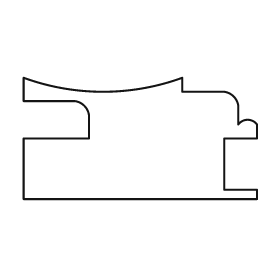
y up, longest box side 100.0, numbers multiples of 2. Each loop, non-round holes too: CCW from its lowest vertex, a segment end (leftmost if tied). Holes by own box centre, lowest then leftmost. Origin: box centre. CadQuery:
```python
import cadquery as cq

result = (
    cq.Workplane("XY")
    .moveTo(-50.0, -26.0)
    .lineTo(50.0, -26.0)
    .lineTo(50.0, -22.0)
    .lineTo(36.0, -22.0)
    .lineTo(36.0, 0.0)
    .lineTo(50.0, 0.0)
    .lineTo(50.0, 6.0)
    .threePointArc((46.0, 8.0), (42.0, 6.0))
    .lineTo(42.0, 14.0)
    .threePointArc((40.0, 18.0), (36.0, 20.0))
    .lineTo(18.0, 20.0)
    .lineTo(18.0, 26.0)
    .threePointArc((-16.0, 20.0), (-50.0, 26.0))
    .lineTo(-50.0, 16.0)
    .lineTo(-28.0, 16.0)
    .threePointArc((-24.0, 14.0), (-22.0, 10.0))
    .lineTo(-22.0, 0.0)
    .lineTo(-50.0, 0.0)
    .close()
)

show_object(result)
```